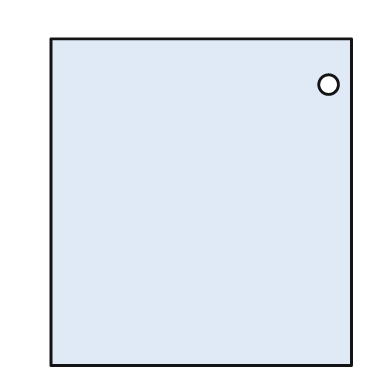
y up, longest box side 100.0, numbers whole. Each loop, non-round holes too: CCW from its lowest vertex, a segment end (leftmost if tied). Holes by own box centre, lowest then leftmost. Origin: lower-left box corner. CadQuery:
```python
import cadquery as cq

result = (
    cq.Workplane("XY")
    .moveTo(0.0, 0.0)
    .lineTo(92.0, 0.0)
    .lineTo(92.0, 100.0)
    .lineTo(0.0, 100.0)
    .close()
    .moveTo(85.0, 86.0)
    .circle(3.0)
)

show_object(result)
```